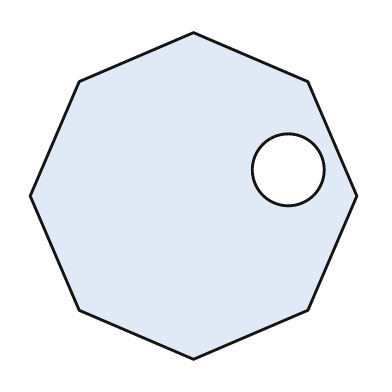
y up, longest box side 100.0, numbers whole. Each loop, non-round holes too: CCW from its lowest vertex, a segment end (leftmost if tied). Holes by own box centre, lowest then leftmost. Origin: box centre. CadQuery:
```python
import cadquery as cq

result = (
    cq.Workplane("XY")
    .moveTo(0.0, -50.0)
    .lineTo(35.0, -35.0)
    .lineTo(50.0, 0.0)
    .lineTo(35.0, 35.0)
    .lineTo(0.0, 50.0)
    .lineTo(-35.0, 35.0)
    .lineTo(-50.0, 0.0)
    .lineTo(-35.0, -35.0)
    .close()
    .moveTo(29.0, 8.0)
    .circle(11.0)
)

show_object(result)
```